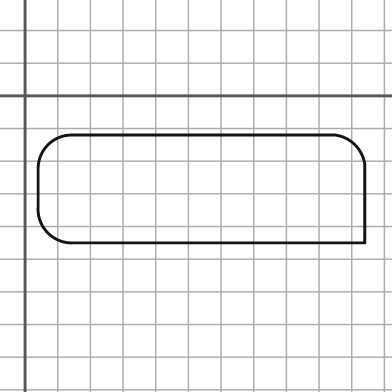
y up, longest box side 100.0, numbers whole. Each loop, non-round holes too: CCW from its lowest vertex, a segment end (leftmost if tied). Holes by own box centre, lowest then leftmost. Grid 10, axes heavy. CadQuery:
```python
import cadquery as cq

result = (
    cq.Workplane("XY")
    .moveTo(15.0, -45.0)
    .lineTo(104.0, -45.0)
    .lineTo(104.0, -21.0)
    .threePointArc((101.0, -15.0), (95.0, -12.0))
    .lineTo(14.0, -12.0)
    .threePointArc((7.0, -15.0), (4.0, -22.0))
    .lineTo(4.0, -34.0)
    .threePointArc((7.0, -42.0), (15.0, -45.0))
    .close()
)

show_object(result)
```